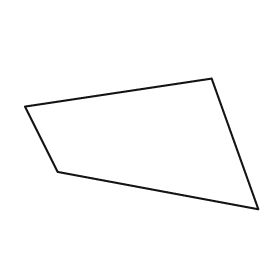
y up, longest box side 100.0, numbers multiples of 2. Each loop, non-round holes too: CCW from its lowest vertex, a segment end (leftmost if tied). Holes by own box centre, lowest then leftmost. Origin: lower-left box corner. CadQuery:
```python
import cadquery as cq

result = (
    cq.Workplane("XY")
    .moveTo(100.0, 0.0)
    .lineTo(80.0, 56.0)
    .lineTo(0.0, 44.0)
    .lineTo(14.0, 16.0)
    .close()
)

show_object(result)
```